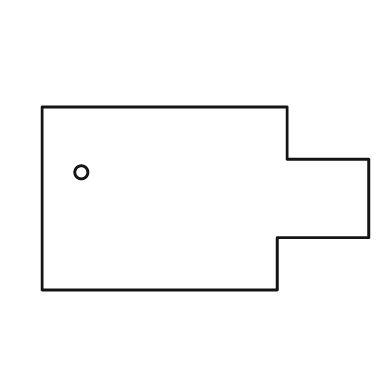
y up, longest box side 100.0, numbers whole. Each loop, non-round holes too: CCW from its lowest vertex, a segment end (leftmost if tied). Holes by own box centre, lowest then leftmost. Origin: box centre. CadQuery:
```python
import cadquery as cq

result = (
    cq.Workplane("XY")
    .moveTo(-50.0, -28.0)
    .lineTo(22.0, -28.0)
    .lineTo(22.0, -12.0)
    .lineTo(50.0, -12.0)
    .lineTo(50.0, 12.0)
    .lineTo(25.0, 12.0)
    .lineTo(25.0, 28.0)
    .lineTo(-50.0, 28.0)
    .close()
    .moveTo(-38.0, 8.0)
    .circle(2.0)
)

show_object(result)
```